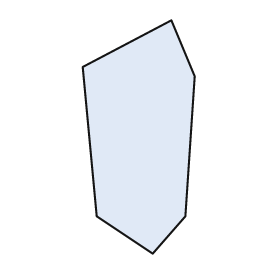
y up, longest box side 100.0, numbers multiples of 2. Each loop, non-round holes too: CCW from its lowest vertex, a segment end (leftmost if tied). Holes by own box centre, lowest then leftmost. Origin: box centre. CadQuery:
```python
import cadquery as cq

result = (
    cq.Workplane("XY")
    .moveTo(6.0, -50.0)
    .lineTo(20.0, -34.0)
    .lineTo(24.0, 26.0)
    .lineTo(14.0, 50.0)
    .lineTo(-24.0, 30.0)
    .lineTo(-18.0, -34.0)
    .close()
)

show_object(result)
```